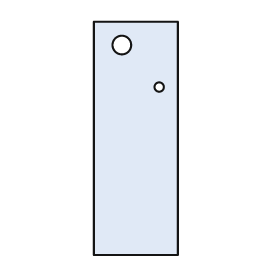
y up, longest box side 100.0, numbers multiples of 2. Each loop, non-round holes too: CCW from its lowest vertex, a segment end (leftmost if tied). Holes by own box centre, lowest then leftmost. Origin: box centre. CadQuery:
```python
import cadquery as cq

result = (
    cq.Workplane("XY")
    .moveTo(-18.0, -50.0)
    .lineTo(18.0, -50.0)
    .lineTo(18.0, 50.0)
    .lineTo(-18.0, 50.0)
    .close()
    .moveTo(10.0, 22.0)
    .circle(2.0)
    .moveTo(-6.0, 40.0)
    .circle(4.0)
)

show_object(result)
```